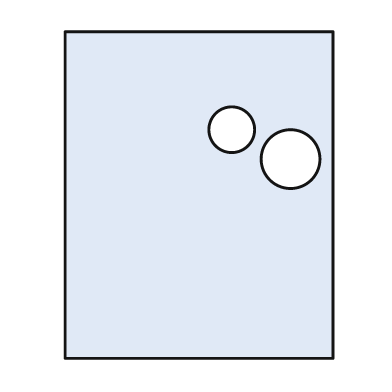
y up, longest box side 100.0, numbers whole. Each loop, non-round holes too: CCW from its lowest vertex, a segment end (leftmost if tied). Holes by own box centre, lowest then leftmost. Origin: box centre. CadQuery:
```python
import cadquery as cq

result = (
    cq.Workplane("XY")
    .moveTo(-41.0, -50.0)
    .lineTo(41.0, -50.0)
    .lineTo(41.0, 50.0)
    .lineTo(-41.0, 50.0)
    .close()
    .moveTo(28.0, 11.0)
    .circle(9.0)
    .moveTo(10.0, 20.0)
    .circle(7.0)
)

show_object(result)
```